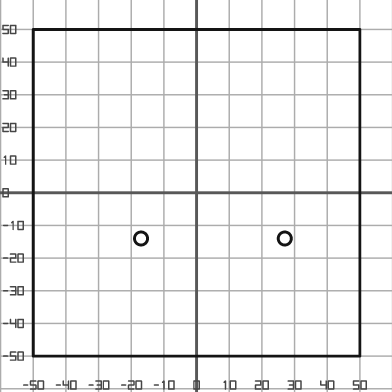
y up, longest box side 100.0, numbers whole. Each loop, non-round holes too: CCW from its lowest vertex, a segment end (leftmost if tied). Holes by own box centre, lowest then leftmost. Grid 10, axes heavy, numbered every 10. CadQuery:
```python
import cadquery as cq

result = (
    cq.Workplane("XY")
    .moveTo(-50.0, -50.0)
    .lineTo(50.0, -50.0)
    .lineTo(50.0, 50.0)
    .lineTo(-50.0, 50.0)
    .close()
    .moveTo(-17.0, -14.0)
    .circle(2.0)
    .moveTo(27.0, -14.0)
    .circle(2.0)
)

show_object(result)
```